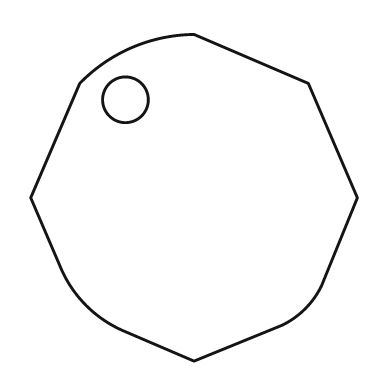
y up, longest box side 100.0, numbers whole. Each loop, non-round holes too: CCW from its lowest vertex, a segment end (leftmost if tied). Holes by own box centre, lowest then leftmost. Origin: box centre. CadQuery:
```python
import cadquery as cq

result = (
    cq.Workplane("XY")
    .moveTo(0.0, -50.0)
    .lineTo(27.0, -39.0)
    .threePointArc((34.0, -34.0), (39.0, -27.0))
    .lineTo(50.0, 0.0)
    .lineTo(35.0, 35.0)
    .lineTo(0.0, 50.0)
    .threePointArc((-19.0, 46.0), (-35.0, 35.0))
    .lineTo(-50.0, 0.0)
    .lineTo(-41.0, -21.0)
    .threePointArc((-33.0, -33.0), (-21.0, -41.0))
    .close()
    .moveTo(-21.0, 30.0)
    .circle(7.0)
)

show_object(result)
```